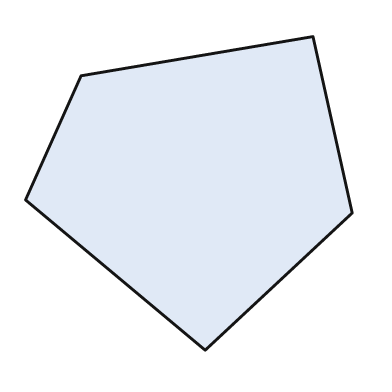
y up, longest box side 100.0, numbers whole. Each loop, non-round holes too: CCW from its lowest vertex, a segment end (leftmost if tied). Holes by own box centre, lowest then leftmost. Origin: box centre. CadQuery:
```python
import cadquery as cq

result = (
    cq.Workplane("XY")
    .moveTo(5.0, -48.0)
    .lineTo(50.0, -6.0)
    .lineTo(38.0, 48.0)
    .lineTo(-33.0, 36.0)
    .lineTo(-50.0, -2.0)
    .close()
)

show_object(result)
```